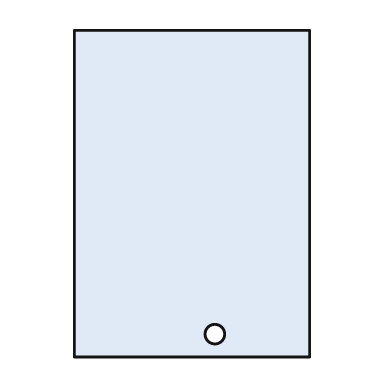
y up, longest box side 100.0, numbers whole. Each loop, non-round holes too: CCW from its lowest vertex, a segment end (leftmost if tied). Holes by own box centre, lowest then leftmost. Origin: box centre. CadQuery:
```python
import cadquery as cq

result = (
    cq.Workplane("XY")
    .moveTo(-36.0, -50.0)
    .lineTo(36.0, -50.0)
    .lineTo(36.0, 50.0)
    .lineTo(-36.0, 50.0)
    .close()
    .moveTo(7.0, -43.0)
    .circle(3.0)
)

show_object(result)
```